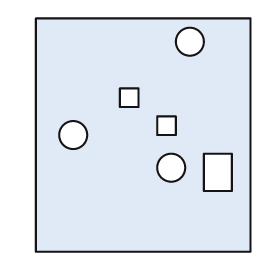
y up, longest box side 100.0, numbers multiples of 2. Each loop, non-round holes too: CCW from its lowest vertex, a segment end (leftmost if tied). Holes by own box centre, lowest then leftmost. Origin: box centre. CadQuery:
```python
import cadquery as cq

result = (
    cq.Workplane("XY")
    .moveTo(-46.0, -50.0)
    .lineTo(46.0, -50.0)
    .lineTo(46.0, 50.0)
    .lineTo(-46.0, 50.0)
    .close()
    .moveTo(26.0, -24.0)
    .lineTo(38.0, -24.0)
    .lineTo(38.0, -8.0)
    .lineTo(26.0, -8.0)
    .close()
    .moveTo(12.0, -14.0)
    .circle(6.0)
    .moveTo(-30.0, 0.0)
    .circle(6.0)
    .moveTo(6.0, 0.0)
    .lineTo(14.0, 0.0)
    .lineTo(14.0, 8.0)
    .lineTo(6.0, 8.0)
    .close()
    .moveTo(-10.0, 12.0)
    .lineTo(-2.0, 12.0)
    .lineTo(-2.0, 20.0)
    .lineTo(-10.0, 20.0)
    .close()
    .moveTo(20.0, 40.0)
    .circle(6.0)
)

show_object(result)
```